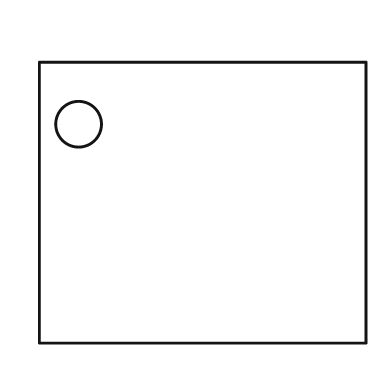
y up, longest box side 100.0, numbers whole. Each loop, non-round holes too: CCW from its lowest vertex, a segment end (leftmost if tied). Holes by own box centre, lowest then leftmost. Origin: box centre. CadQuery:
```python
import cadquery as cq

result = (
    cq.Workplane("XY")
    .moveTo(-50.0, -43.0)
    .lineTo(50.0, -43.0)
    .lineTo(50.0, 43.0)
    .lineTo(-50.0, 43.0)
    .close()
    .moveTo(-38.0, 24.0)
    .circle(7.0)
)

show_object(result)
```